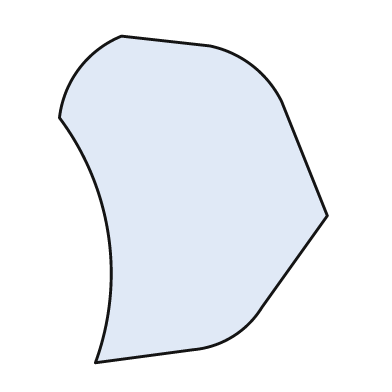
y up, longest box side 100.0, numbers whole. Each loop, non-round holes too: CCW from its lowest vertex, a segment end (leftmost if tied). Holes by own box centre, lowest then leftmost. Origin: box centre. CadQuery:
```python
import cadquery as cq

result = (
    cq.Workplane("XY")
    .moveTo(-30.0, -50.0)
    .lineTo(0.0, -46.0)
    .threePointArc((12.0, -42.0), (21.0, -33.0))
    .lineTo(41.0, -5.0)
    .lineTo(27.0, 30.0)
    .threePointArc((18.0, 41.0), (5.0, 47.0))
    .lineTo(-22.0, 50.0)
    .threePointArc((-35.0, 40.0), (-41.0, 25.0))
    .threePointArc((-26.0, -11.0), (-30.0, -50.0))
    .close()
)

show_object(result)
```